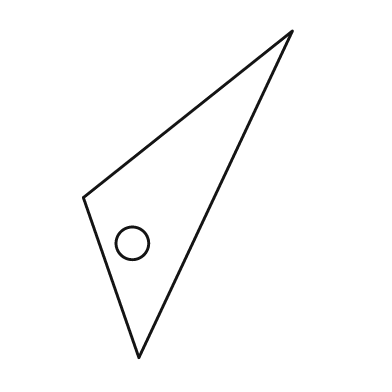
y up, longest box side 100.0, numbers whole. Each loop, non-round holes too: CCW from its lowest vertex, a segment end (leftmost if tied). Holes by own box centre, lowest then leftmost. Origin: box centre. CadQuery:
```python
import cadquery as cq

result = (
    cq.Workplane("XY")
    .moveTo(-15.0, -50.0)
    .lineTo(32.0, 50.0)
    .lineTo(-32.0, -1.0)
    .close()
    .moveTo(-17.0, -15.0)
    .circle(5.0)
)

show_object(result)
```